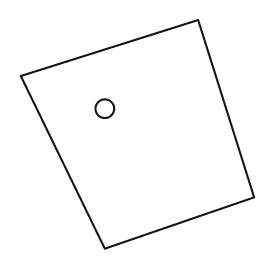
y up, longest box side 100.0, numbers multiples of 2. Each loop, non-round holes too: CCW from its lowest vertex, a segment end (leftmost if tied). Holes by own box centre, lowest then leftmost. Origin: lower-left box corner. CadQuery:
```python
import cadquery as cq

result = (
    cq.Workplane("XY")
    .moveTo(36.0, 0.0)
    .lineTo(100.0, 22.0)
    .lineTo(76.0, 98.0)
    .lineTo(0.0, 74.0)
    .close()
    .moveTo(36.0, 60.0)
    .circle(4.0)
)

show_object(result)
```